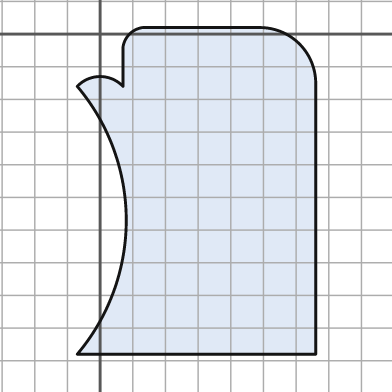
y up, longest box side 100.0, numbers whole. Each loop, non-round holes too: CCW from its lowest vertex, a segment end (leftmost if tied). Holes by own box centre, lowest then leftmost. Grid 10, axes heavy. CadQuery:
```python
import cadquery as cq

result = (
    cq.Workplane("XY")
    .moveTo(-7.0, -98.0)
    .lineTo(66.0, -98.0)
    .lineTo(66.0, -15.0)
    .threePointArc((61.0, -3.0), (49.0, 2.0))
    .lineTo(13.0, 2.0)
    .threePointArc((9.0, 0.0), (7.0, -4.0))
    .lineTo(7.0, -16.0)
    .threePointArc((0.0, -13.0), (-7.0, -16.0))
    .threePointArc((8.0, -57.0), (-7.0, -98.0))
    .close()
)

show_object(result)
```